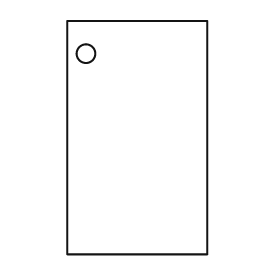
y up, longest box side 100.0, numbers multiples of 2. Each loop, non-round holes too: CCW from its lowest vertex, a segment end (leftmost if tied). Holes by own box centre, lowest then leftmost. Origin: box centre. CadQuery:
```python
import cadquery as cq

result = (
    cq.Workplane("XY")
    .moveTo(-30.0, -50.0)
    .lineTo(30.0, -50.0)
    .lineTo(30.0, 50.0)
    .lineTo(-30.0, 50.0)
    .close()
    .moveTo(-22.0, 36.0)
    .circle(4.0)
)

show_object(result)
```